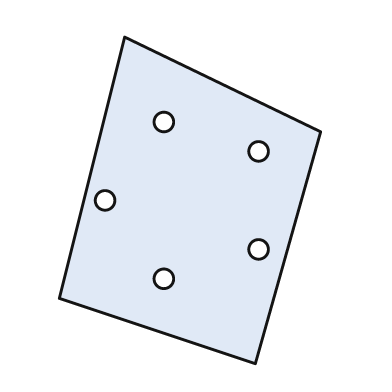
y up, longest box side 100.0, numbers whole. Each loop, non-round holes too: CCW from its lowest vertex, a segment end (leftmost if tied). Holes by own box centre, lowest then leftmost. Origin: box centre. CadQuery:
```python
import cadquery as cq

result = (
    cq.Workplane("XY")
    .moveTo(20.0, -50.0)
    .lineTo(40.0, 21.0)
    .lineTo(-20.0, 50.0)
    .lineTo(-40.0, -30.0)
    .close()
    .moveTo(-8.0, -24.0)
    .circle(3.0)
    .moveTo(21.0, -15.0)
    .circle(3.0)
    .moveTo(-26.0, 0.0)
    .circle(3.0)
    .moveTo(21.0, 15.0)
    .circle(3.0)
    .moveTo(-8.0, 24.0)
    .circle(3.0)
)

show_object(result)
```